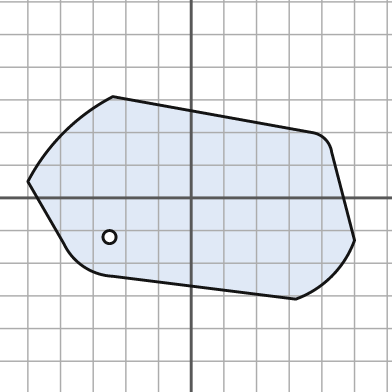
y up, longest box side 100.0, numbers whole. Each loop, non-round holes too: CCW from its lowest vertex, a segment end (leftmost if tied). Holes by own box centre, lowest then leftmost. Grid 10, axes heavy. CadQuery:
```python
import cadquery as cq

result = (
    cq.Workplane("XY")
    .moveTo(32.0, -31.0)
    .threePointArc((43.0, -24.0), (50.0, -13.0))
    .lineTo(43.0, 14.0)
    .threePointArc((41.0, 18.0), (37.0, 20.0))
    .lineTo(-24.0, 31.0)
    .threePointArc((-39.0, 20.0), (-50.0, 5.0))
    .lineTo(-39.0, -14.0)
    .threePointArc((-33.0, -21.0), (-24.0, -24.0))
    .close()
    .moveTo(-25.0, -12.0)
    .circle(2.0)
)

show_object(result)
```